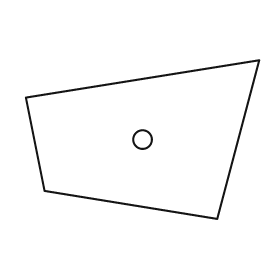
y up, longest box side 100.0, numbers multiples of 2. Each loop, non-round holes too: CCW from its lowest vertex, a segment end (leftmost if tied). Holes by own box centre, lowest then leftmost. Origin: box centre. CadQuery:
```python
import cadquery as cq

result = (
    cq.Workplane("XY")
    .moveTo(32.0, -34.0)
    .lineTo(50.0, 34.0)
    .lineTo(-50.0, 18.0)
    .lineTo(-42.0, -22.0)
    .close()
    .moveTo(0.0, 0.0)
    .circle(4.0)
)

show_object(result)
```